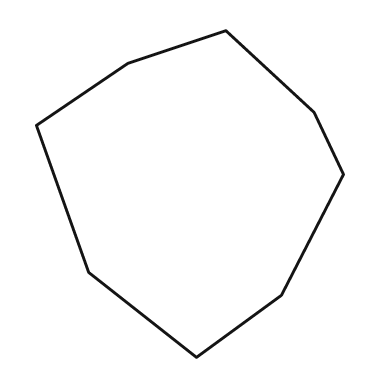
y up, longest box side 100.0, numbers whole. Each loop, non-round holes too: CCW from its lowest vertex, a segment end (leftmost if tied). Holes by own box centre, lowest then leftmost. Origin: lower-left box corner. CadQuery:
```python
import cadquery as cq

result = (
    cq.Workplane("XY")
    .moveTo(49.0, 0.0)
    .lineTo(75.0, 19.0)
    .lineTo(94.0, 56.0)
    .lineTo(85.0, 75.0)
    .lineTo(58.0, 100.0)
    .lineTo(28.0, 90.0)
    .lineTo(0.0, 71.0)
    .lineTo(16.0, 26.0)
    .close()
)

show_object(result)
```